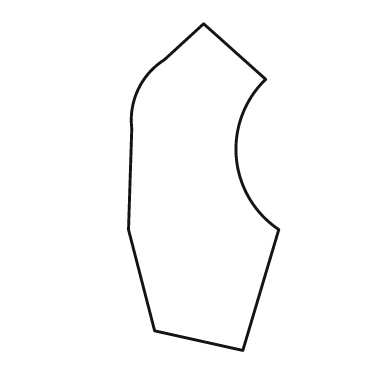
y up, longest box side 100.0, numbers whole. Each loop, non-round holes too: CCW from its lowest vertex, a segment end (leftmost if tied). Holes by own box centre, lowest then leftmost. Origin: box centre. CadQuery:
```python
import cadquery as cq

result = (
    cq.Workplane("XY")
    .moveTo(12.0, -50.0)
    .lineTo(23.0, -13.0)
    .threePointArc((10.0, 9.0), (19.0, 33.0))
    .lineTo(0.0, 50.0)
    .lineTo(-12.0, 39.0)
    .threePointArc((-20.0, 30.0), (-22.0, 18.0))
    .lineTo(-23.0, -13.0)
    .lineTo(-15.0, -44.0)
    .close()
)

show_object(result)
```